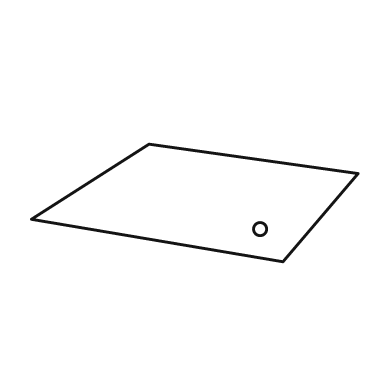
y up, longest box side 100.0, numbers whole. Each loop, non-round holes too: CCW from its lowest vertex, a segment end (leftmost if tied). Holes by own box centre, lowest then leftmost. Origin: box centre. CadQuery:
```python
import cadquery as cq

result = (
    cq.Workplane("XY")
    .moveTo(27.0, -18.0)
    .lineTo(50.0, 9.0)
    .lineTo(-14.0, 18.0)
    .lineTo(-50.0, -5.0)
    .close()
    .moveTo(20.0, -8.0)
    .circle(2.0)
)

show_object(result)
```